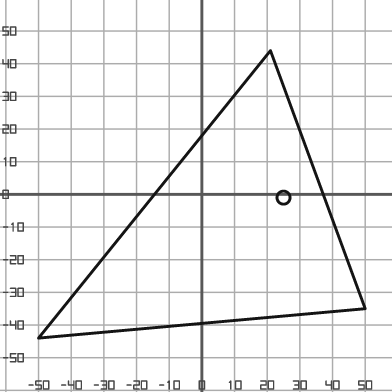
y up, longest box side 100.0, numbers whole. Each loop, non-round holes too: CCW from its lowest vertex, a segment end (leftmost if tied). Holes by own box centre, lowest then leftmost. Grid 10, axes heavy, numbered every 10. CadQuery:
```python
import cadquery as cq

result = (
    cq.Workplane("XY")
    .moveTo(-50.0, -44.0)
    .lineTo(50.0, -35.0)
    .lineTo(21.0, 44.0)
    .close()
    .moveTo(25.0, -1.0)
    .circle(2.0)
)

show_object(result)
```